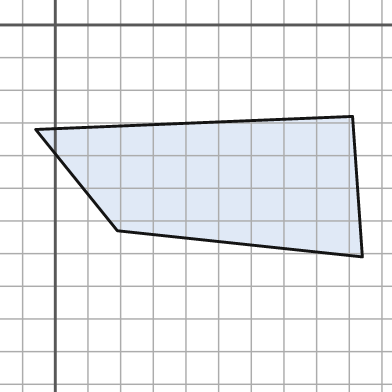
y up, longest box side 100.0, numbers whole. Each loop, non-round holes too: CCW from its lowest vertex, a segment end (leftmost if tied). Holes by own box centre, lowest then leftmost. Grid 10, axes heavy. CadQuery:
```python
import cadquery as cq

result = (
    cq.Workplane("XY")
    .moveTo(94.0, -71.0)
    .lineTo(91.0, -28.0)
    .lineTo(-6.0, -32.0)
    .lineTo(19.0, -63.0)
    .close()
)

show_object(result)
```